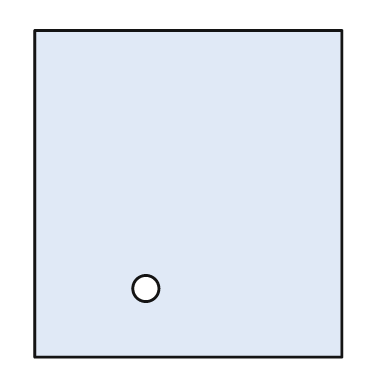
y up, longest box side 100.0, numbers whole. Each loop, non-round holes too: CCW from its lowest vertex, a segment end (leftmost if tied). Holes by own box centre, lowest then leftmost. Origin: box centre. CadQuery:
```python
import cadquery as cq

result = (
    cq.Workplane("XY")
    .moveTo(-47.0, -50.0)
    .lineTo(47.0, -50.0)
    .lineTo(47.0, 50.0)
    .lineTo(-47.0, 50.0)
    .close()
    .moveTo(-13.0, -29.0)
    .circle(4.0)
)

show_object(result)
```